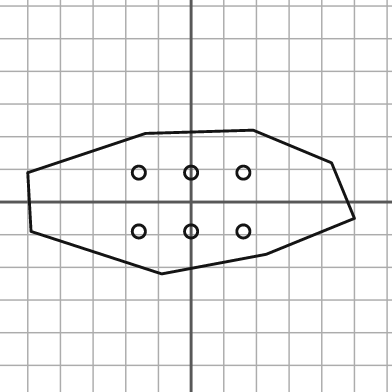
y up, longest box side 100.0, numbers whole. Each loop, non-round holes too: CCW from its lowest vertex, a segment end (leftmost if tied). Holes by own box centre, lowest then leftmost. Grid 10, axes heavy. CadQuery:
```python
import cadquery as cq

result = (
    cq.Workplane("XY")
    .moveTo(-9.0, -22.0)
    .lineTo(23.0, -16.0)
    .lineTo(50.0, -5.0)
    .lineTo(43.0, 12.0)
    .lineTo(19.0, 22.0)
    .lineTo(-14.0, 21.0)
    .lineTo(-50.0, 9.0)
    .lineTo(-49.0, -9.0)
    .close()
    .moveTo(-16.0, -9.0)
    .circle(2.0)
    .moveTo(0.0, -9.0)
    .circle(2.0)
    .moveTo(16.0, -9.0)
    .circle(2.0)
    .moveTo(-16.0, 9.0)
    .circle(2.0)
    .moveTo(0.0, 9.0)
    .circle(2.0)
    .moveTo(16.0, 9.0)
    .circle(2.0)
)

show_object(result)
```